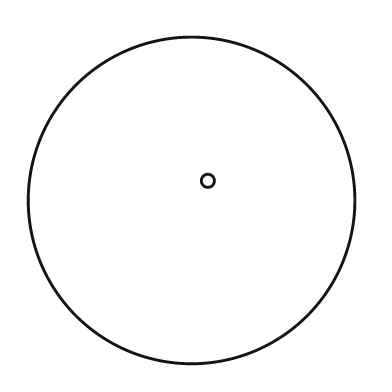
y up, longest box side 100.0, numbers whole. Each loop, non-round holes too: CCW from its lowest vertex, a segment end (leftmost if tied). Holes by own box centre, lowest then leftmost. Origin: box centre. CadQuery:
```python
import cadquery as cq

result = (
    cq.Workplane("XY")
    .moveTo(0.0, 0.0)
    .circle(50.0)
    .moveTo(5.0, 6.0)
    .circle(2.0)
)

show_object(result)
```